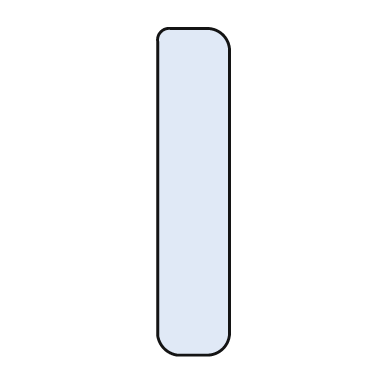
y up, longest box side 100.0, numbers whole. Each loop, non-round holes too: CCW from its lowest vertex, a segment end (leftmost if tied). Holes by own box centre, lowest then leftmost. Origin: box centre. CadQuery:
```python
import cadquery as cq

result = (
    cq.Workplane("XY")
    .moveTo(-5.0, -50.0)
    .lineTo(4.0, -50.0)
    .threePointArc((9.0, -48.0), (11.0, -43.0))
    .lineTo(11.0, 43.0)
    .threePointArc((9.0, 48.0), (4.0, 50.0))
    .lineTo(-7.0, 50.0)
    .threePointArc((-10.0, 49.0), (-11.0, 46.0))
    .lineTo(-11.0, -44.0)
    .threePointArc((-9.0, -48.0), (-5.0, -50.0))
    .close()
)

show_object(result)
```